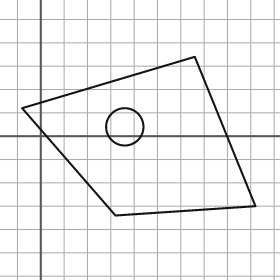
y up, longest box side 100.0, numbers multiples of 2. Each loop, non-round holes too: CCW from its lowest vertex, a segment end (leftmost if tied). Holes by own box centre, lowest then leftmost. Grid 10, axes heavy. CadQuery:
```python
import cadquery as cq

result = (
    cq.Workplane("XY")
    .moveTo(32.0, -34.0)
    .lineTo(92.0, -30.0)
    .lineTo(66.0, 34.0)
    .lineTo(-8.0, 12.0)
    .close()
    .moveTo(36.0, 4.0)
    .circle(8.0)
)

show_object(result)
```